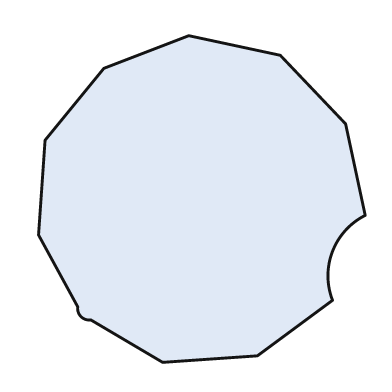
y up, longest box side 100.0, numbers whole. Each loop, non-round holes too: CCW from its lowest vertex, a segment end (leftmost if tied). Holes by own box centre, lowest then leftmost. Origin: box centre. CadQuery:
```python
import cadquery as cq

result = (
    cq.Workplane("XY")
    .moveTo(-12.0, -50.0)
    .lineTo(17.0, -48.0)
    .lineTo(40.0, -31.0)
    .threePointArc((40.0, -16.0), (50.0, -5.0))
    .lineTo(44.0, 23.0)
    .lineTo(24.0, 44.0)
    .lineTo(-4.0, 50.0)
    .lineTo(-30.0, 40.0)
    .lineTo(-48.0, 18.0)
    .lineTo(-50.0, -11.0)
    .lineTo(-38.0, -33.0)
    .threePointArc((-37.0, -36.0), (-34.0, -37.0))
    .close()
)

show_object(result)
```